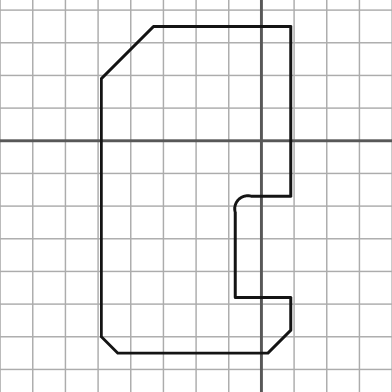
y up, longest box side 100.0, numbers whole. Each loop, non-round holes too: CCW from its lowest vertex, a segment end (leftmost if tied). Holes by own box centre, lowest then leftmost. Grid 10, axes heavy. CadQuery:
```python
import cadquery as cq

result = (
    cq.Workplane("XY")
    .moveTo(-44.0, -65.0)
    .lineTo(2.0, -65.0)
    .lineTo(9.0, -58.0)
    .lineTo(9.0, -48.0)
    .lineTo(-8.0, -48.0)
    .lineTo(-8.0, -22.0)
    .threePointArc((-7.0, -18.0), (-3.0, -17.0))
    .lineTo(9.0, -17.0)
    .lineTo(9.0, 35.0)
    .lineTo(-33.0, 35.0)
    .lineTo(-49.0, 19.0)
    .lineTo(-49.0, -60.0)
    .close()
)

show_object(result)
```